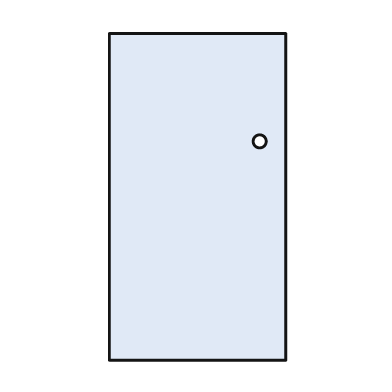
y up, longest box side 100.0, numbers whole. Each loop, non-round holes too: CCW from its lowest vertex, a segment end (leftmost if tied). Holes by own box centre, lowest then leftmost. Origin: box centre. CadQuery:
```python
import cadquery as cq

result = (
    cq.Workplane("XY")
    .moveTo(-27.0, -50.0)
    .lineTo(27.0, -50.0)
    .lineTo(27.0, 50.0)
    .lineTo(-27.0, 50.0)
    .close()
    .moveTo(19.0, 17.0)
    .circle(2.0)
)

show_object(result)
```